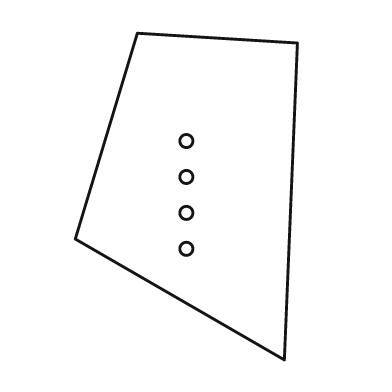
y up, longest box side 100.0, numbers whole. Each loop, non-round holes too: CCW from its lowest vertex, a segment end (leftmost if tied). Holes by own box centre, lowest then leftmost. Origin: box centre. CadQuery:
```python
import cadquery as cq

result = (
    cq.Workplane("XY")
    .moveTo(30.0, -50.0)
    .lineTo(34.0, 47.0)
    .lineTo(-15.0, 50.0)
    .lineTo(-34.0, -13.0)
    .close()
    .moveTo(0.0, -16.0)
    .circle(2.0)
    .moveTo(0.0, -5.0)
    .circle(2.0)
    .moveTo(0.0, 6.0)
    .circle(2.0)
    .moveTo(0.0, 17.0)
    .circle(2.0)
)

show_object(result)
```